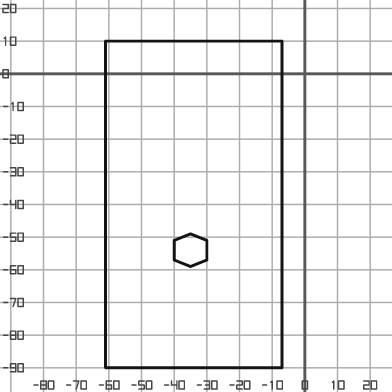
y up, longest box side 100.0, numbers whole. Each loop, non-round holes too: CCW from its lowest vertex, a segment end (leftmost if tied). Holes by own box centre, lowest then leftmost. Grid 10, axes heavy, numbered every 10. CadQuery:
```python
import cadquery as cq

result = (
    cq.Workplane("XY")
    .moveTo(-61.0, -90.0)
    .lineTo(-7.0, -90.0)
    .lineTo(-7.0, 10.0)
    .lineTo(-61.0, 10.0)
    .close()
    .moveTo(-35.0, -59.0)
    .lineTo(-30.0, -57.0)
    .lineTo(-30.0, -51.0)
    .lineTo(-35.0, -49.0)
    .lineTo(-40.0, -51.0)
    .lineTo(-40.0, -57.0)
    .close()
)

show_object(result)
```